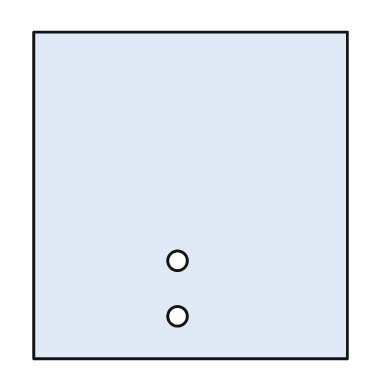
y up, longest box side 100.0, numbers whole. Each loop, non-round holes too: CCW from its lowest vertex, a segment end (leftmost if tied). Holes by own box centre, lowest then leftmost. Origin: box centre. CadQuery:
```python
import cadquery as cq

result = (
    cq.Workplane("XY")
    .moveTo(-48.0, -50.0)
    .lineTo(48.0, -50.0)
    .lineTo(48.0, 50.0)
    .lineTo(-48.0, 50.0)
    .close()
    .moveTo(-4.0, -37.0)
    .circle(3.0)
    .moveTo(-4.0, -20.0)
    .circle(3.0)
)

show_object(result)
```